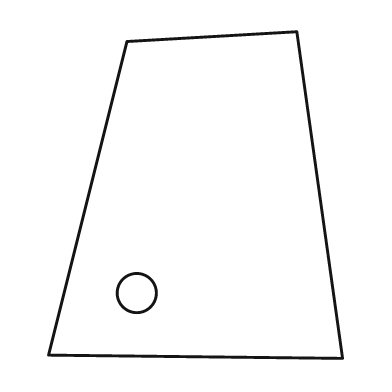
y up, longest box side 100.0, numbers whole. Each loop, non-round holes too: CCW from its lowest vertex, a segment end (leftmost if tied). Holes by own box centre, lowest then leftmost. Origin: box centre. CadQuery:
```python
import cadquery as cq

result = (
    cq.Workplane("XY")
    .moveTo(45.0, -50.0)
    .lineTo(31.0, 50.0)
    .lineTo(-21.0, 47.0)
    .lineTo(-45.0, -49.0)
    .close()
    .moveTo(-18.0, -30.0)
    .circle(6.0)
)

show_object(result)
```